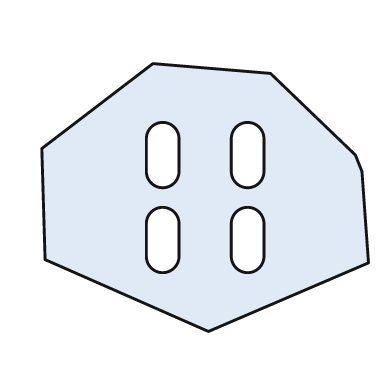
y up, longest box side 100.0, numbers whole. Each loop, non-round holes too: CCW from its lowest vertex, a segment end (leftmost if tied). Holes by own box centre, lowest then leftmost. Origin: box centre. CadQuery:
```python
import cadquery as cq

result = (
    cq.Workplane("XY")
    .moveTo(1.0, -41.0)
    .lineTo(50.0, -20.0)
    .lineTo(48.0, 8.0)
    .lineTo(46.0, 13.0)
    .lineTo(20.0, 38.0)
    .lineTo(-16.0, 41.0)
    .lineTo(-50.0, 15.0)
    .lineTo(-49.0, -19.0)
    .close()
    .moveTo(-18.0, -18.0)
    .threePointArc((-13.0, -23.0), (-8.0, -18.0))
    .lineTo(-8.0, -8.0)
    .threePointArc((-13.0, -3.0), (-18.0, -8.0))
    .close()
    .moveTo(8.0, -18.0)
    .threePointArc((13.0, -23.0), (18.0, -18.0))
    .lineTo(18.0, -8.0)
    .threePointArc((13.0, -3.0), (8.0, -8.0))
    .close()
    .moveTo(-18.0, 8.0)
    .threePointArc((-13.0, 3.0), (-8.0, 8.0))
    .lineTo(-8.0, 18.0)
    .threePointArc((-13.0, 23.0), (-18.0, 18.0))
    .close()
    .moveTo(8.0, 8.0)
    .threePointArc((13.0, 3.0), (18.0, 8.0))
    .lineTo(18.0, 18.0)
    .threePointArc((13.0, 23.0), (8.0, 18.0))
    .close()
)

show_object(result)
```